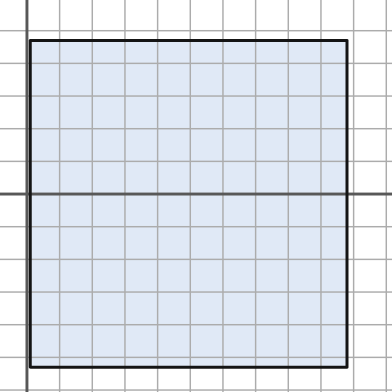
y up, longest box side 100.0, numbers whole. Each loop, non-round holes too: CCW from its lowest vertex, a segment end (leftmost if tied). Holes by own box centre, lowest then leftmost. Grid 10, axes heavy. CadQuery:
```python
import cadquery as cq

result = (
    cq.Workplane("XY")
    .moveTo(1.0, -53.0)
    .lineTo(98.0, -53.0)
    .lineTo(98.0, 47.0)
    .lineTo(1.0, 47.0)
    .close()
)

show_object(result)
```